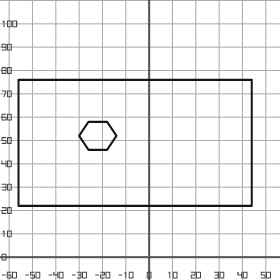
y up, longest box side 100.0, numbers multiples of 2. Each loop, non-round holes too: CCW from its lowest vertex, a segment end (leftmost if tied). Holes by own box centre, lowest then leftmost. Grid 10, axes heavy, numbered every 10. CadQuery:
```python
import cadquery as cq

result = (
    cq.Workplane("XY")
    .moveTo(-56.0, 22.0)
    .lineTo(44.0, 22.0)
    .lineTo(44.0, 76.0)
    .lineTo(-56.0, 76.0)
    .close()
    .moveTo(-26.0, 46.0)
    .lineTo(-18.0, 46.0)
    .lineTo(-14.0, 52.0)
    .lineTo(-18.0, 58.0)
    .lineTo(-26.0, 58.0)
    .lineTo(-30.0, 52.0)
    .close()
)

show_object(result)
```